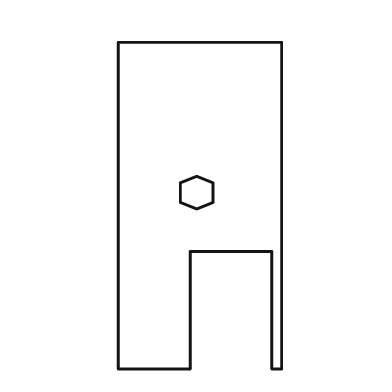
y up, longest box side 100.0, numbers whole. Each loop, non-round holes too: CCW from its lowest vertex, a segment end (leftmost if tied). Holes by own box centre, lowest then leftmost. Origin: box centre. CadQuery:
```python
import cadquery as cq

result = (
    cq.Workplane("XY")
    .moveTo(-25.0, -50.0)
    .lineTo(-3.0, -50.0)
    .lineTo(-3.0, -14.0)
    .lineTo(22.0, -14.0)
    .lineTo(22.0, -50.0)
    .lineTo(25.0, -50.0)
    .lineTo(25.0, 50.0)
    .lineTo(-25.0, 50.0)
    .close()
    .moveTo(-1.0, -1.0)
    .lineTo(4.0, 1.0)
    .lineTo(4.0, 7.0)
    .lineTo(-1.0, 9.0)
    .lineTo(-6.0, 7.0)
    .lineTo(-6.0, 1.0)
    .close()
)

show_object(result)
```